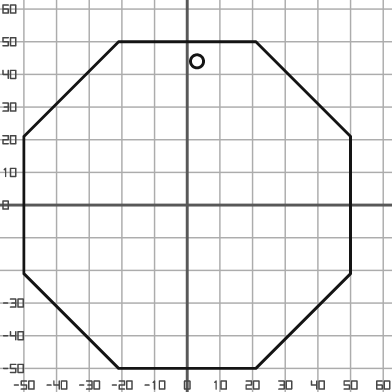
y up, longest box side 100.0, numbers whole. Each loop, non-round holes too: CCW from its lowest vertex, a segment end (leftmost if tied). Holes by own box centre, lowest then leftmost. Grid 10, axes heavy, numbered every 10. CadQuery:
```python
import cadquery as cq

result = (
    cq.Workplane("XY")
    .moveTo(-21.0, -50.0)
    .lineTo(21.0, -50.0)
    .lineTo(50.0, -21.0)
    .lineTo(50.0, 21.0)
    .lineTo(21.0, 50.0)
    .lineTo(-21.0, 50.0)
    .lineTo(-50.0, 21.0)
    .lineTo(-50.0, -21.0)
    .close()
    .moveTo(3.0, 44.0)
    .circle(2.0)
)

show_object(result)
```